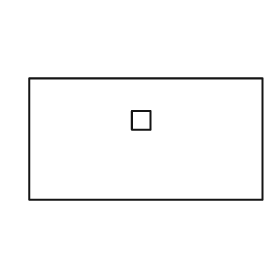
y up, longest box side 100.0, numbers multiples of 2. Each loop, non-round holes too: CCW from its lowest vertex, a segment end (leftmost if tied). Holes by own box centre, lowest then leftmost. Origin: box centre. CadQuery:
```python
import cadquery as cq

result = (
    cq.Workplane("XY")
    .moveTo(-50.0, -26.0)
    .lineTo(50.0, -26.0)
    .lineTo(50.0, 26.0)
    .lineTo(-50.0, 26.0)
    .close()
    .moveTo(-6.0, 4.0)
    .lineTo(2.0, 4.0)
    .lineTo(2.0, 12.0)
    .lineTo(-6.0, 12.0)
    .close()
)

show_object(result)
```